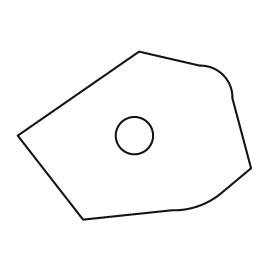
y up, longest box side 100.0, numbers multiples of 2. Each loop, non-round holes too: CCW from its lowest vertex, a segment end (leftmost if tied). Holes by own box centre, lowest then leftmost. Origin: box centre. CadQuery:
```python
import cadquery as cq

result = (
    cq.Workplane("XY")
    .moveTo(-22.0, -36.0)
    .lineTo(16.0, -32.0)
    .threePointArc((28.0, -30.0), (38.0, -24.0))
    .lineTo(50.0, -14.0)
    .lineTo(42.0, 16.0)
    .threePointArc((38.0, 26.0), (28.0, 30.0))
    .lineTo(2.0, 36.0)
    .lineTo(-50.0, 0.0)
    .close()
    .moveTo(0.0, 0.0)
    .circle(8.0)
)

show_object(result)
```